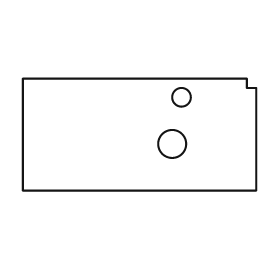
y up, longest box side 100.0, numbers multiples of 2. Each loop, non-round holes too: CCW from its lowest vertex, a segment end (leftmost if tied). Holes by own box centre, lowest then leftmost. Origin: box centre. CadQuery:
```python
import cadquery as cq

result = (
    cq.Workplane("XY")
    .moveTo(-50.0, -24.0)
    .lineTo(50.0, -24.0)
    .lineTo(50.0, 20.0)
    .lineTo(46.0, 20.0)
    .lineTo(46.0, 24.0)
    .lineTo(-50.0, 24.0)
    .close()
    .moveTo(14.0, -4.0)
    .circle(6.0)
    .moveTo(18.0, 16.0)
    .circle(4.0)
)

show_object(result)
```